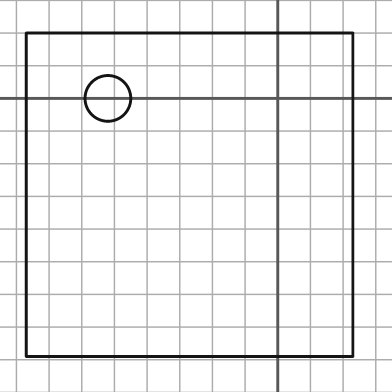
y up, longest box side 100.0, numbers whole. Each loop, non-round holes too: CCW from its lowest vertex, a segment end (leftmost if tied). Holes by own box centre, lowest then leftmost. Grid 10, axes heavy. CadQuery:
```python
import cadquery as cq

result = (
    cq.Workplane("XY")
    .moveTo(-77.0, -79.0)
    .lineTo(23.0, -79.0)
    .lineTo(23.0, 20.0)
    .lineTo(-77.0, 20.0)
    .close()
    .moveTo(-52.0, 0.0)
    .circle(7.0)
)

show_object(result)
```